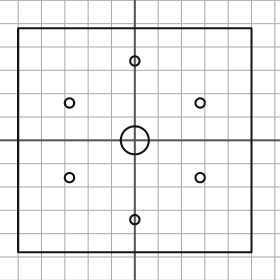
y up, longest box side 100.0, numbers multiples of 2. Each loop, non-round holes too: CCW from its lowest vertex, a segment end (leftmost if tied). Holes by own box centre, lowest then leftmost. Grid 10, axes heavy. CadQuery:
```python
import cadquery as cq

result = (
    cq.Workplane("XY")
    .moveTo(-50.0, -48.0)
    .lineTo(50.0, -48.0)
    .lineTo(50.0, 48.0)
    .lineTo(-50.0, 48.0)
    .close()
    .moveTo(0.0, -34.0)
    .circle(2.0)
    .moveTo(-28.0, -16.0)
    .circle(2.0)
    .moveTo(28.0, -16.0)
    .circle(2.0)
    .moveTo(0.0, 0.0)
    .circle(6.0)
    .moveTo(-28.0, 16.0)
    .circle(2.0)
    .moveTo(28.0, 16.0)
    .circle(2.0)
    .moveTo(0.0, 34.0)
    .circle(2.0)
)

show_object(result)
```